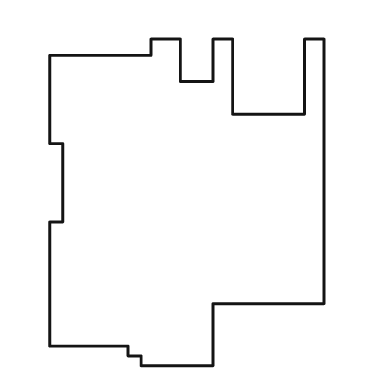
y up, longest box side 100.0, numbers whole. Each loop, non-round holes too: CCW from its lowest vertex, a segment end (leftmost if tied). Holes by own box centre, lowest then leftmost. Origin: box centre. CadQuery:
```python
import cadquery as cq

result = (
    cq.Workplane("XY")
    .moveTo(-14.0, -50.0)
    .lineTo(8.0, -50.0)
    .lineTo(8.0, -31.0)
    .lineTo(42.0, -31.0)
    .lineTo(42.0, 50.0)
    .lineTo(36.0, 50.0)
    .lineTo(36.0, 27.0)
    .lineTo(14.0, 27.0)
    .lineTo(14.0, 50.0)
    .lineTo(8.0, 50.0)
    .lineTo(8.0, 37.0)
    .lineTo(-2.0, 37.0)
    .lineTo(-2.0, 50.0)
    .lineTo(-11.0, 50.0)
    .lineTo(-11.0, 45.0)
    .lineTo(-42.0, 45.0)
    .lineTo(-42.0, 18.0)
    .lineTo(-38.0, 18.0)
    .lineTo(-38.0, -6.0)
    .lineTo(-42.0, -6.0)
    .lineTo(-42.0, -44.0)
    .lineTo(-18.0, -44.0)
    .lineTo(-18.0, -47.0)
    .lineTo(-14.0, -47.0)
    .close()
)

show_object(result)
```